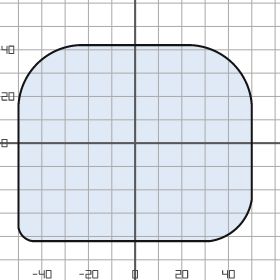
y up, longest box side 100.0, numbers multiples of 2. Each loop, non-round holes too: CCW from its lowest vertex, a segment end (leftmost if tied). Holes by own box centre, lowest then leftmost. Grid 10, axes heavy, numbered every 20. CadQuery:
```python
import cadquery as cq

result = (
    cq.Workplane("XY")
    .moveTo(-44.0, -42.0)
    .lineTo(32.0, -42.0)
    .threePointArc((44.0, -36.0), (50.0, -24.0))
    .lineTo(50.0, 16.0)
    .threePointArc((42.0, 34.0), (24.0, 42.0))
    .lineTo(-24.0, 42.0)
    .threePointArc((-42.0, 34.0), (-50.0, 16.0))
    .lineTo(-50.0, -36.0)
    .threePointArc((-48.0, -40.0), (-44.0, -42.0))
    .close()
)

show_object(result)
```